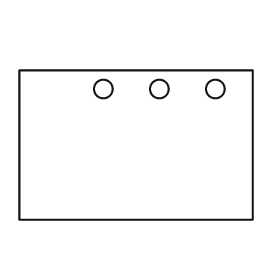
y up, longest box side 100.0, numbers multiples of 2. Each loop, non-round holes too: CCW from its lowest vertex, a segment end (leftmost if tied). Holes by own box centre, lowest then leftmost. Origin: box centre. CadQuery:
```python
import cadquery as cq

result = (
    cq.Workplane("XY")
    .moveTo(-50.0, -32.0)
    .lineTo(50.0, -32.0)
    .lineTo(50.0, 32.0)
    .lineTo(-50.0, 32.0)
    .close()
    .moveTo(-14.0, 24.0)
    .circle(4.0)
    .moveTo(10.0, 24.0)
    .circle(4.0)
    .moveTo(34.0, 24.0)
    .circle(4.0)
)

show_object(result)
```